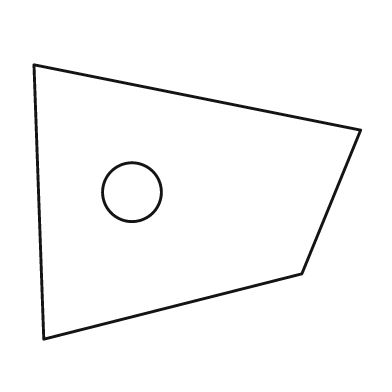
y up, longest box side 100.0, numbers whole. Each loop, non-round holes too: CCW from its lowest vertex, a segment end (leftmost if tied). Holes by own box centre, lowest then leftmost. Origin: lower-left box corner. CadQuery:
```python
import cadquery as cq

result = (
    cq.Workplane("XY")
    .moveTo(3.0, 0.0)
    .lineTo(82.0, 20.0)
    .lineTo(100.0, 64.0)
    .lineTo(0.0, 84.0)
    .close()
    .moveTo(30.0, 45.0)
    .circle(9.0)
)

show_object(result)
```